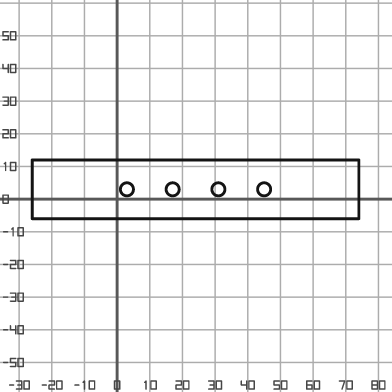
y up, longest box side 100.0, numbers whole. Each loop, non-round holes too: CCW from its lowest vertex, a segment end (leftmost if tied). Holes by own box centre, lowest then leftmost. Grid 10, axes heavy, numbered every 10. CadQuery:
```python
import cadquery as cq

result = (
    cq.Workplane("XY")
    .moveTo(-26.0, -6.0)
    .lineTo(74.0, -6.0)
    .lineTo(74.0, 12.0)
    .lineTo(-26.0, 12.0)
    .close()
    .moveTo(3.0, 3.0)
    .circle(2.0)
    .moveTo(17.0, 3.0)
    .circle(2.0)
    .moveTo(31.0, 3.0)
    .circle(2.0)
    .moveTo(45.0, 3.0)
    .circle(2.0)
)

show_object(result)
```